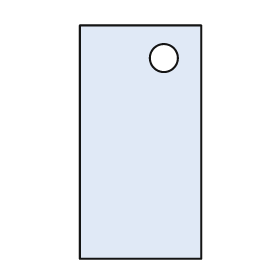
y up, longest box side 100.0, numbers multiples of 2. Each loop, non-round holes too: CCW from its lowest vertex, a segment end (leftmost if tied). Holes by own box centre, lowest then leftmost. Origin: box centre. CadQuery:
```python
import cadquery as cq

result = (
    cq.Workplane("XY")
    .moveTo(-26.0, -50.0)
    .lineTo(26.0, -50.0)
    .lineTo(26.0, 50.0)
    .lineTo(-26.0, 50.0)
    .close()
    .moveTo(10.0, 36.0)
    .circle(6.0)
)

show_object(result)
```